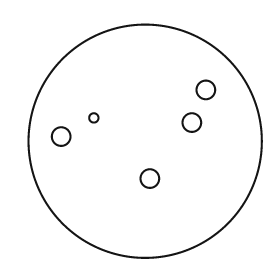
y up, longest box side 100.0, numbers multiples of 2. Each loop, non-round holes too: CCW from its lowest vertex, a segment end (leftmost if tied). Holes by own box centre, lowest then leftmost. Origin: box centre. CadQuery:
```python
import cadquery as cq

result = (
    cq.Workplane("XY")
    .moveTo(0.0, 0.0)
    .circle(50.0)
    .moveTo(2.0, -16.0)
    .circle(4.0)
    .moveTo(-36.0, 2.0)
    .circle(4.0)
    .moveTo(20.0, 8.0)
    .circle(4.0)
    .moveTo(-22.0, 10.0)
    .circle(2.0)
    .moveTo(26.0, 22.0)
    .circle(4.0)
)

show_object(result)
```